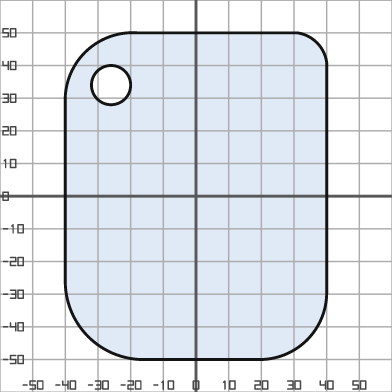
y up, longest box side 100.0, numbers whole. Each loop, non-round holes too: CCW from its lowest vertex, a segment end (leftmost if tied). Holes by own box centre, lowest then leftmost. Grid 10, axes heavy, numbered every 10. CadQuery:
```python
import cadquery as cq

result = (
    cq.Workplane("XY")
    .moveTo(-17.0, -50.0)
    .lineTo(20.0, -50.0)
    .threePointArc((34.0, -44.0), (40.0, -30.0))
    .lineTo(40.0, 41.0)
    .threePointArc((37.0, 47.0), (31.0, 50.0))
    .lineTo(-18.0, 50.0)
    .threePointArc((-34.0, 44.0), (-40.0, 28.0))
    .lineTo(-40.0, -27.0)
    .threePointArc((-33.0, -43.0), (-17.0, -50.0))
    .close()
    .moveTo(-26.0, 34.0)
    .circle(6.0)
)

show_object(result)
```